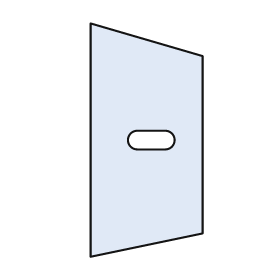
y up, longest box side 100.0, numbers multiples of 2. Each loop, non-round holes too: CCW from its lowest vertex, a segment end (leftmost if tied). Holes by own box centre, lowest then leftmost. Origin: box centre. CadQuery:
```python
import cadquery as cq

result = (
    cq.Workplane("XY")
    .moveTo(-24.0, -50.0)
    .lineTo(24.0, -40.0)
    .lineTo(24.0, 36.0)
    .lineTo(-24.0, 50.0)
    .close()
    .moveTo(-4.0, -4.0)
    .lineTo(8.0, -4.0)
    .threePointArc((12.0, 0.0), (8.0, 4.0))
    .lineTo(-4.0, 4.0)
    .threePointArc((-8.0, 0.0), (-4.0, -4.0))
    .close()
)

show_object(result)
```